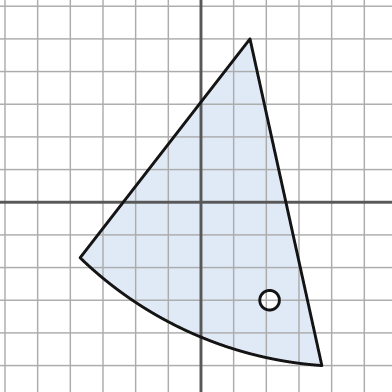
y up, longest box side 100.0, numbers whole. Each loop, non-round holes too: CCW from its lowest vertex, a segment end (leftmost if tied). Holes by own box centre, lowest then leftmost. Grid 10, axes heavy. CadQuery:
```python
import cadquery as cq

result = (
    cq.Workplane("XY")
    .moveTo(37.0, -50.0)
    .lineTo(15.0, 50.0)
    .lineTo(-37.0, -17.0)
    .threePointArc((-3.0, -40.0), (37.0, -50.0))
    .close()
    .moveTo(21.0, -30.0)
    .circle(3.0)
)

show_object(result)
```